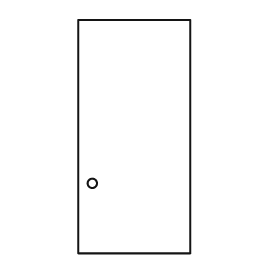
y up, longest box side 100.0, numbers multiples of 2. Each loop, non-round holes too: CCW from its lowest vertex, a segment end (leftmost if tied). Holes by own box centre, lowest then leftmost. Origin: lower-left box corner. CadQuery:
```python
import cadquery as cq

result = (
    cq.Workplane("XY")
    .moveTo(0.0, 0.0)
    .lineTo(48.0, 0.0)
    .lineTo(48.0, 100.0)
    .lineTo(0.0, 100.0)
    .close()
    .moveTo(6.0, 30.0)
    .circle(2.0)
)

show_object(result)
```